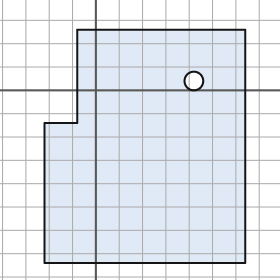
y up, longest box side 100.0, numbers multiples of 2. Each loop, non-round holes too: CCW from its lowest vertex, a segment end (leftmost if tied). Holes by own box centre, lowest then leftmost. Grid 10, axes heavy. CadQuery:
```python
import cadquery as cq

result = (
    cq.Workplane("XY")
    .moveTo(-22.0, -74.0)
    .lineTo(64.0, -74.0)
    .lineTo(64.0, 26.0)
    .lineTo(-8.0, 26.0)
    .lineTo(-8.0, -14.0)
    .lineTo(-22.0, -14.0)
    .close()
    .moveTo(42.0, 4.0)
    .circle(4.0)
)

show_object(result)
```